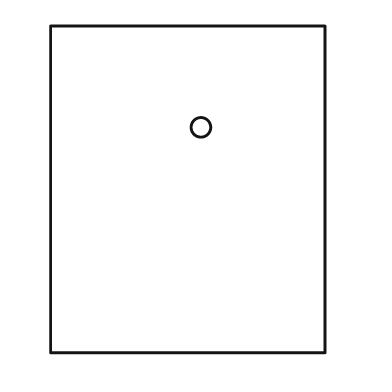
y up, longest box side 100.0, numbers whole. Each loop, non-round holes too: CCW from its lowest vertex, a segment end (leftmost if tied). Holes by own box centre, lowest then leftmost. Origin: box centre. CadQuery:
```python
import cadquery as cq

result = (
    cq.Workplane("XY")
    .moveTo(-42.0, -50.0)
    .lineTo(42.0, -50.0)
    .lineTo(42.0, 50.0)
    .lineTo(-42.0, 50.0)
    .close()
    .moveTo(4.0, 19.0)
    .circle(3.0)
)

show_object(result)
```